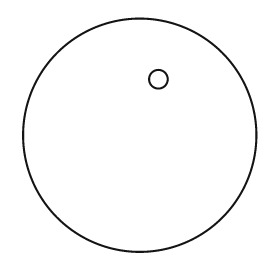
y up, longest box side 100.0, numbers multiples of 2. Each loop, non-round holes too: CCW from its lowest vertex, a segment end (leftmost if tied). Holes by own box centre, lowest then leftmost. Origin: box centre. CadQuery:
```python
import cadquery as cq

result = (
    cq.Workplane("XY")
    .moveTo(0.0, 0.0)
    .circle(50.0)
    .moveTo(8.0, 24.0)
    .circle(4.0)
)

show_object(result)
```